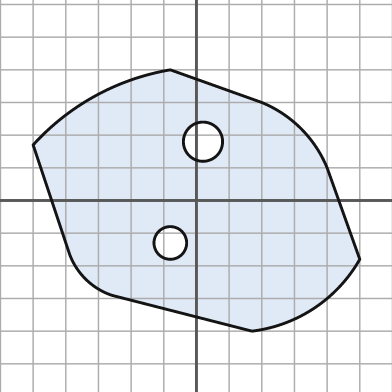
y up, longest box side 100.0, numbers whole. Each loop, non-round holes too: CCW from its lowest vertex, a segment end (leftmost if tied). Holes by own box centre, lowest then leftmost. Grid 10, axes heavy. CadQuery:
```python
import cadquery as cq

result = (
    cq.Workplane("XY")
    .moveTo(17.0, -40.0)
    .threePointArc((36.0, -33.0), (50.0, -18.0))
    .lineTo(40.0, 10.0)
    .threePointArc((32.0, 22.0), (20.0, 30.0))
    .lineTo(-8.0, 40.0)
    .threePointArc((-31.0, 32.0), (-50.0, 17.0))
    .lineTo(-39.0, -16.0)
    .threePointArc((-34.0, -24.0), (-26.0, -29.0))
    .close()
    .moveTo(-8.0, -13.0)
    .circle(5.0)
    .moveTo(2.0, 18.0)
    .circle(6.0)
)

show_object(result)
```